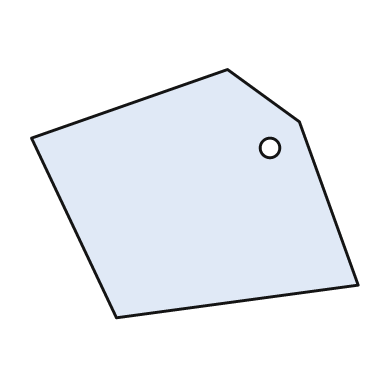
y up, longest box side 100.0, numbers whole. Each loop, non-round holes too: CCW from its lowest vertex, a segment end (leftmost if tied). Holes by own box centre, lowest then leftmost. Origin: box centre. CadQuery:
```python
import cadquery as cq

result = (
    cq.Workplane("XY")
    .moveTo(-24.0, -38.0)
    .lineTo(50.0, -28.0)
    .lineTo(32.0, 22.0)
    .lineTo(10.0, 38.0)
    .lineTo(-50.0, 17.0)
    .close()
    .moveTo(23.0, 14.0)
    .circle(3.0)
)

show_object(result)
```